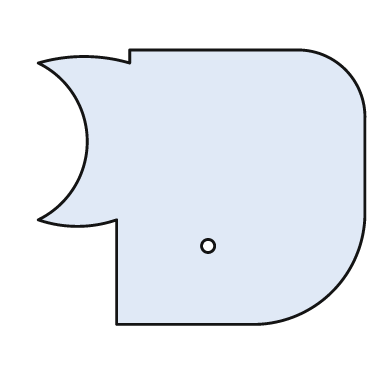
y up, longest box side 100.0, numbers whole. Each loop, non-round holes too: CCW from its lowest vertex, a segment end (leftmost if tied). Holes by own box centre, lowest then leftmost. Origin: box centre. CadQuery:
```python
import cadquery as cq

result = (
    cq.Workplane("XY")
    .moveTo(-26.0, -42.0)
    .lineTo(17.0, -42.0)
    .threePointArc((40.0, -32.0), (50.0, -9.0))
    .lineTo(50.0, 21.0)
    .threePointArc((44.0, 36.0), (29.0, 42.0))
    .lineTo(-22.0, 42.0)
    .lineTo(-22.0, 38.0)
    .threePointArc((-36.0, 40.0), (-50.0, 38.0))
    .threePointArc((-35.0, 14.0), (-50.0, -10.0))
    .threePointArc((-38.0, -12.0), (-26.0, -10.0))
    .close()
    .moveTo(2.0, -18.0)
    .circle(2.0)
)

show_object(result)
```